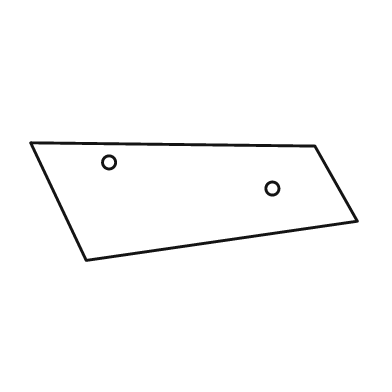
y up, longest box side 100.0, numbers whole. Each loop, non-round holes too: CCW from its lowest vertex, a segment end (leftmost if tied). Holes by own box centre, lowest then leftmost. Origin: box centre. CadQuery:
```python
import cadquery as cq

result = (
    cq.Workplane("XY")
    .moveTo(-33.0, -18.0)
    .lineTo(50.0, -6.0)
    .lineTo(37.0, 17.0)
    .lineTo(-50.0, 18.0)
    .close()
    .moveTo(24.0, 4.0)
    .circle(2.0)
    .moveTo(-26.0, 12.0)
    .circle(2.0)
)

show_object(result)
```